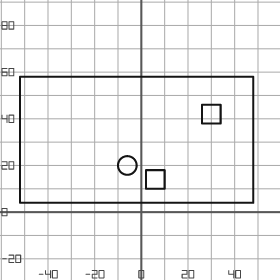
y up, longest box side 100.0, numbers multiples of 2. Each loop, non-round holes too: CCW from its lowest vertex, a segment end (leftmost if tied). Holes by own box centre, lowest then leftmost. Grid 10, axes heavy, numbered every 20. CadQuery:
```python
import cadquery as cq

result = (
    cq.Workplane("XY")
    .moveTo(-52.0, 4.0)
    .lineTo(48.0, 4.0)
    .lineTo(48.0, 58.0)
    .lineTo(-52.0, 58.0)
    .close()
    .moveTo(2.0, 10.0)
    .lineTo(10.0, 10.0)
    .lineTo(10.0, 18.0)
    .lineTo(2.0, 18.0)
    .close()
    .moveTo(-6.0, 20.0)
    .circle(4.0)
    .moveTo(26.0, 38.0)
    .lineTo(34.0, 38.0)
    .lineTo(34.0, 46.0)
    .lineTo(26.0, 46.0)
    .close()
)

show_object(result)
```